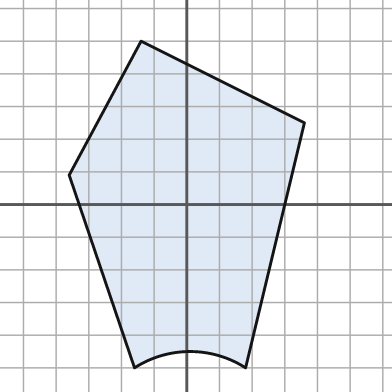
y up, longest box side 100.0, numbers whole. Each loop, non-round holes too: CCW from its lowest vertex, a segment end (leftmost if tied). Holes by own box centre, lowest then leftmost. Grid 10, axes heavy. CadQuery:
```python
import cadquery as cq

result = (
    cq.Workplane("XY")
    .moveTo(-16.0, -50.0)
    .threePointArc((1.0, -45.0), (18.0, -50.0))
    .lineTo(36.0, 25.0)
    .lineTo(-14.0, 50.0)
    .lineTo(-36.0, 9.0)
    .close()
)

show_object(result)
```